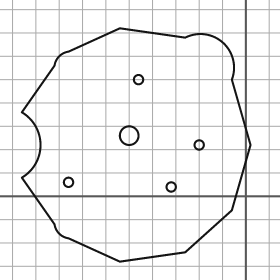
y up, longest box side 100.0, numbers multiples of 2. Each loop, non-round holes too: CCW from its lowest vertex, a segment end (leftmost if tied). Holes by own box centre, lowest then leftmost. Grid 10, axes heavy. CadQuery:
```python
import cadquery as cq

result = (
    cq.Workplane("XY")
    .moveTo(-54.0, -28.0)
    .lineTo(-26.0, -24.0)
    .lineTo(-6.0, -6.0)
    .lineTo(2.0, 22.0)
    .lineTo(-6.0, 50.0)
    .threePointArc((-10.0, 66.0), (-26.0, 68.0))
    .lineTo(-54.0, 72.0)
    .lineTo(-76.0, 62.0)
    .threePointArc((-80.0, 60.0), (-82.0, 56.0))
    .lineTo(-96.0, 36.0)
    .threePointArc((-88.0, 22.0), (-96.0, 8.0))
    .lineTo(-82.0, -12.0)
    .threePointArc((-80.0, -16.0), (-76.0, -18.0))
    .close()
    .moveTo(-32.0, 4.0)
    .circle(2.0)
    .moveTo(-76.0, 6.0)
    .circle(2.0)
    .moveTo(-20.0, 22.0)
    .circle(2.0)
    .moveTo(-50.0, 26.0)
    .circle(4.0)
    .moveTo(-46.0, 50.0)
    .circle(2.0)
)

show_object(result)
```